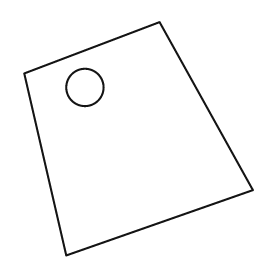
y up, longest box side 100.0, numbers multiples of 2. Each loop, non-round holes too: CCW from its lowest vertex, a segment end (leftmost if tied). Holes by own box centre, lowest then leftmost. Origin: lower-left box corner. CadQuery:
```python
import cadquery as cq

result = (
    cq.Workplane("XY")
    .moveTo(18.0, 0.0)
    .lineTo(98.0, 28.0)
    .lineTo(58.0, 100.0)
    .lineTo(0.0, 78.0)
    .close()
    .moveTo(26.0, 72.0)
    .circle(8.0)
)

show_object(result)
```